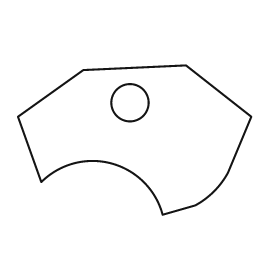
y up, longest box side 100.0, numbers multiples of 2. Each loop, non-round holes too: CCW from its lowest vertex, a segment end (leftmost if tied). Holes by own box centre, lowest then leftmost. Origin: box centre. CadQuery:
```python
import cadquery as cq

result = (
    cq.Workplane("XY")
    .moveTo(12.0, -32.0)
    .lineTo(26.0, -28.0)
    .threePointArc((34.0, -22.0), (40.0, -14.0))
    .lineTo(50.0, 10.0)
    .lineTo(22.0, 32.0)
    .lineTo(-22.0, 30.0)
    .lineTo(-50.0, 10.0)
    .lineTo(-40.0, -18.0)
    .threePointArc((-10.0, -10.0), (12.0, -32.0))
    .close()
    .moveTo(-2.0, 16.0)
    .circle(8.0)
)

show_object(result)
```